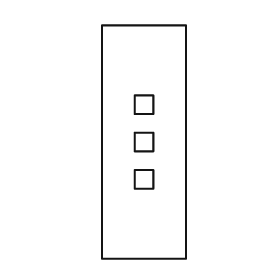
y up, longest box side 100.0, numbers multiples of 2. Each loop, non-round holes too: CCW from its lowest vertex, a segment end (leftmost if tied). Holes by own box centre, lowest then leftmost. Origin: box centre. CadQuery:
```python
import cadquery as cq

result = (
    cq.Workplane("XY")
    .moveTo(-18.0, -50.0)
    .lineTo(18.0, -50.0)
    .lineTo(18.0, 50.0)
    .lineTo(-18.0, 50.0)
    .close()
    .moveTo(-4.0, -20.0)
    .lineTo(4.0, -20.0)
    .lineTo(4.0, -12.0)
    .lineTo(-4.0, -12.0)
    .close()
    .moveTo(-4.0, -4.0)
    .lineTo(4.0, -4.0)
    .lineTo(4.0, 4.0)
    .lineTo(-4.0, 4.0)
    .close()
    .moveTo(-4.0, 12.0)
    .lineTo(4.0, 12.0)
    .lineTo(4.0, 20.0)
    .lineTo(-4.0, 20.0)
    .close()
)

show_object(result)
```